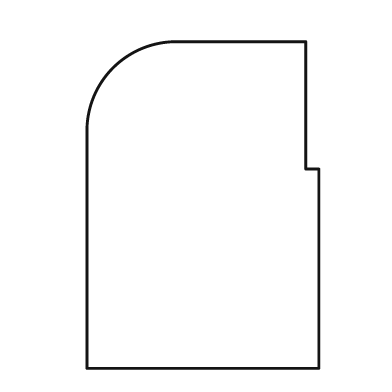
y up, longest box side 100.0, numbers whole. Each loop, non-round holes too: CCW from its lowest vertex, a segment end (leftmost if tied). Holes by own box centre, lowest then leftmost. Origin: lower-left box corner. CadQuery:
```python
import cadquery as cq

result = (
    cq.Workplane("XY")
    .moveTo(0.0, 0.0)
    .lineTo(71.0, 0.0)
    .lineTo(71.0, 61.0)
    .lineTo(67.0, 61.0)
    .lineTo(67.0, 100.0)
    .lineTo(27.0, 100.0)
    .threePointArc((8.0, 92.0), (0.0, 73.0))
    .close()
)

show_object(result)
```